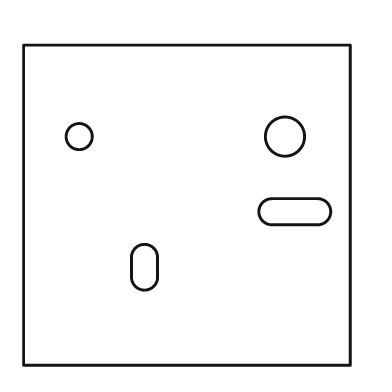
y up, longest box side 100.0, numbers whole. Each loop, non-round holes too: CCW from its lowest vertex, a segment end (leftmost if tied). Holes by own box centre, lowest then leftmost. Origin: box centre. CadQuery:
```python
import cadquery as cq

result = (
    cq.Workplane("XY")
    .moveTo(-50.0, -49.0)
    .lineTo(50.0, -49.0)
    .lineTo(50.0, 49.0)
    .lineTo(-50.0, 49.0)
    .close()
    .moveTo(-17.0, -22.0)
    .threePointArc((-13.0, -26.0), (-9.0, -22.0))
    .lineTo(-9.0, -16.0)
    .threePointArc((-13.0, -12.0), (-17.0, -16.0))
    .close()
    .moveTo(26.0, -6.0)
    .lineTo(40.0, -6.0)
    .threePointArc((44.0, -2.0), (40.0, 2.0))
    .lineTo(26.0, 2.0)
    .threePointArc((22.0, -2.0), (26.0, -6.0))
    .close()
    .moveTo(-33.0, 21.0)
    .circle(4.0)
    .moveTo(30.0, 21.0)
    .circle(6.0)
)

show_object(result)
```